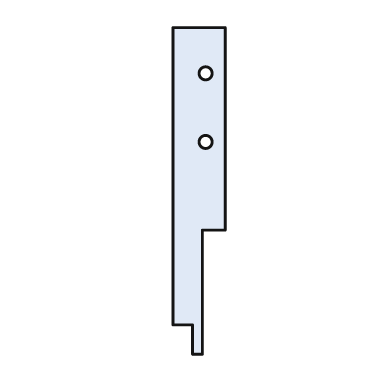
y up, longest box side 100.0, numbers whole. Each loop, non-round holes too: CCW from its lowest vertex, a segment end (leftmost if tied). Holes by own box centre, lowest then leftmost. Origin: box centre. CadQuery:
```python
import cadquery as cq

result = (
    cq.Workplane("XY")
    .moveTo(-2.0, -50.0)
    .lineTo(1.0, -50.0)
    .lineTo(1.0, -12.0)
    .lineTo(8.0, -12.0)
    .lineTo(8.0, 50.0)
    .lineTo(-8.0, 50.0)
    .lineTo(-8.0, -41.0)
    .lineTo(-2.0, -41.0)
    .close()
    .moveTo(2.0, 15.0)
    .circle(2.0)
    .moveTo(2.0, 36.0)
    .circle(2.0)
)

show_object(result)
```